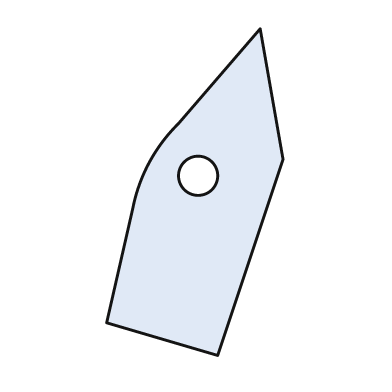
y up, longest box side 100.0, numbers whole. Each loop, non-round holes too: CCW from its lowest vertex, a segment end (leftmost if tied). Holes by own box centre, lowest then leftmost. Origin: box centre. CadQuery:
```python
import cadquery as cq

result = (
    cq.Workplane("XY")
    .moveTo(7.0, -50.0)
    .lineTo(27.0, 10.0)
    .lineTo(20.0, 50.0)
    .lineTo(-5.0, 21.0)
    .threePointArc((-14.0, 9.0), (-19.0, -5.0))
    .lineTo(-27.0, -40.0)
    .close()
    .moveTo(1.0, 5.0)
    .circle(6.0)
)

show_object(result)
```